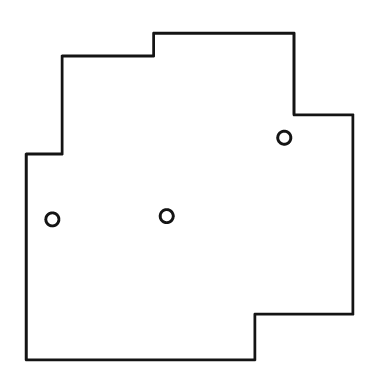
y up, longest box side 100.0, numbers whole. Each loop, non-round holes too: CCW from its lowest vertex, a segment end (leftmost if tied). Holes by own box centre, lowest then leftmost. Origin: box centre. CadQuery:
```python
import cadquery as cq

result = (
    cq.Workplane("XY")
    .moveTo(-50.0, -50.0)
    .lineTo(20.0, -50.0)
    .lineTo(20.0, -36.0)
    .lineTo(50.0, -36.0)
    .lineTo(50.0, 25.0)
    .lineTo(32.0, 25.0)
    .lineTo(32.0, 50.0)
    .lineTo(-11.0, 50.0)
    .lineTo(-11.0, 43.0)
    .lineTo(-39.0, 43.0)
    .lineTo(-39.0, 13.0)
    .lineTo(-50.0, 13.0)
    .close()
    .moveTo(-42.0, -7.0)
    .circle(2.0)
    .moveTo(-7.0, -6.0)
    .circle(2.0)
    .moveTo(29.0, 18.0)
    .circle(2.0)
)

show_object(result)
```